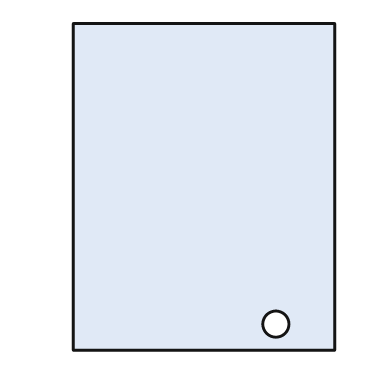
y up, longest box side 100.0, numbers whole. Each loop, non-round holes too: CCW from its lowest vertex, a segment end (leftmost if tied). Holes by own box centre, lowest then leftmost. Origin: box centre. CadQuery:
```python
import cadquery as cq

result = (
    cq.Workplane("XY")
    .moveTo(-40.0, -50.0)
    .lineTo(40.0, -50.0)
    .lineTo(40.0, 50.0)
    .lineTo(-40.0, 50.0)
    .close()
    .moveTo(22.0, -42.0)
    .circle(4.0)
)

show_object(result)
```